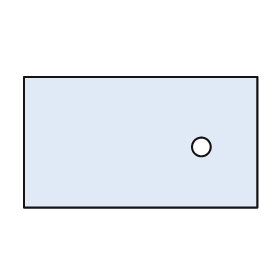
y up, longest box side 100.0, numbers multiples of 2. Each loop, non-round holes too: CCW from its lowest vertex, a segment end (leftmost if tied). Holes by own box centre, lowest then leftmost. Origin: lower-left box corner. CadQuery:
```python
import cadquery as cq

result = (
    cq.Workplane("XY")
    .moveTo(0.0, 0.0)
    .lineTo(100.0, 0.0)
    .lineTo(100.0, 56.0)
    .lineTo(0.0, 56.0)
    .close()
    .moveTo(76.0, 26.0)
    .circle(4.0)
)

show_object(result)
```